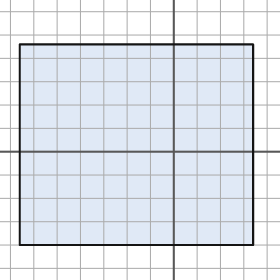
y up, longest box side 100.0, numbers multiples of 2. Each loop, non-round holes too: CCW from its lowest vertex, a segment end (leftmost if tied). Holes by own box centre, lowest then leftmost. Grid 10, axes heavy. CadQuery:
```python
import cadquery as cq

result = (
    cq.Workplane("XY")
    .moveTo(-66.0, -40.0)
    .lineTo(34.0, -40.0)
    .lineTo(34.0, 46.0)
    .lineTo(-66.0, 46.0)
    .close()
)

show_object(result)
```